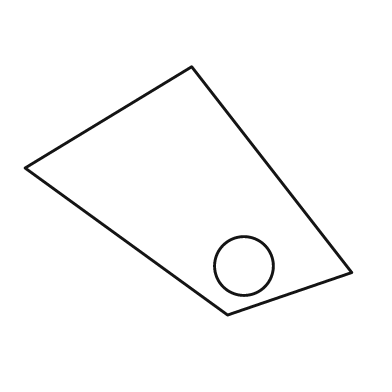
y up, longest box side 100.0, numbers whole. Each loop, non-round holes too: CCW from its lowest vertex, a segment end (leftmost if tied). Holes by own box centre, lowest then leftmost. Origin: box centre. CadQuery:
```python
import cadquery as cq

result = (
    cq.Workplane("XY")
    .moveTo(12.0, -38.0)
    .lineTo(50.0, -25.0)
    .lineTo(1.0, 38.0)
    .lineTo(-50.0, 7.0)
    .close()
    .moveTo(17.0, -23.0)
    .circle(9.0)
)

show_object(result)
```